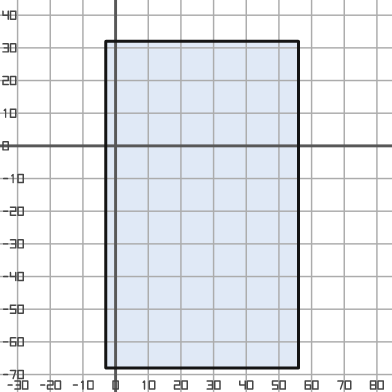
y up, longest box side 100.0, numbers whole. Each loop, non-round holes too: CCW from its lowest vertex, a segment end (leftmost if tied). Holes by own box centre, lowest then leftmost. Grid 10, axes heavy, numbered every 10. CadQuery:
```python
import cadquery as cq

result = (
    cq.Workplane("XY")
    .moveTo(-3.0, -68.0)
    .lineTo(56.0, -68.0)
    .lineTo(56.0, 32.0)
    .lineTo(-3.0, 32.0)
    .close()
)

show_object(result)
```